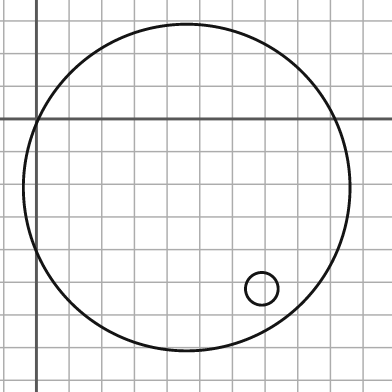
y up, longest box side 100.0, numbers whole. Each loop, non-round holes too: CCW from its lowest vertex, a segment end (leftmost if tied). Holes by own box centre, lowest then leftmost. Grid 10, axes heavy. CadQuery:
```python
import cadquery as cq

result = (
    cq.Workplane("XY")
    .moveTo(46.0, -21.0)
    .circle(50.0)
    .moveTo(69.0, -52.0)
    .circle(5.0)
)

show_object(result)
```